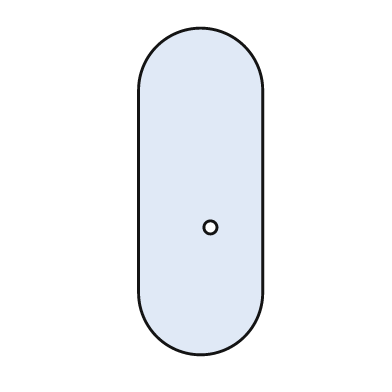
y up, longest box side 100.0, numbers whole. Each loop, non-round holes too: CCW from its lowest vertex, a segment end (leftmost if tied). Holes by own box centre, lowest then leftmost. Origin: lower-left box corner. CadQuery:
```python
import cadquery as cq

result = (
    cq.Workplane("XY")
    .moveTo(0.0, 19.0)
    .threePointArc((19.0, 0.0), (38.0, 19.0))
    .lineTo(38.0, 81.0)
    .threePointArc((19.0, 100.0), (0.0, 81.0))
    .close()
    .moveTo(22.0, 39.0)
    .circle(2.0)
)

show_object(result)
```